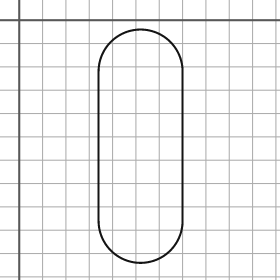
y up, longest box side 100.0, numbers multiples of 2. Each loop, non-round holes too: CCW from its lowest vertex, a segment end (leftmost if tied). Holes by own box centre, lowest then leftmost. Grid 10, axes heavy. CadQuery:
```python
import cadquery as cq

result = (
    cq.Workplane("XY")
    .moveTo(34.0, -86.0)
    .threePointArc((52.0, -104.0), (70.0, -86.0))
    .lineTo(70.0, -22.0)
    .threePointArc((52.0, -4.0), (34.0, -22.0))
    .close()
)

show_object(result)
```